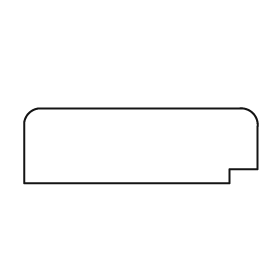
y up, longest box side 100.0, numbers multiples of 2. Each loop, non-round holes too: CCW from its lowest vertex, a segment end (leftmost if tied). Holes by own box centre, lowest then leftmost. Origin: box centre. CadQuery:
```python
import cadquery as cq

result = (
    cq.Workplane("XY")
    .moveTo(-50.0, -16.0)
    .lineTo(38.0, -16.0)
    .lineTo(38.0, -10.0)
    .lineTo(50.0, -10.0)
    .lineTo(50.0, 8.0)
    .threePointArc((48.0, 14.0), (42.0, 16.0))
    .lineTo(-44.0, 16.0)
    .threePointArc((-48.0, 14.0), (-50.0, 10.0))
    .close()
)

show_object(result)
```